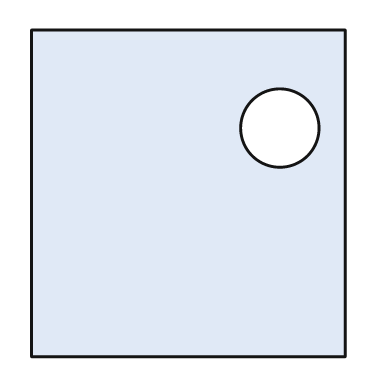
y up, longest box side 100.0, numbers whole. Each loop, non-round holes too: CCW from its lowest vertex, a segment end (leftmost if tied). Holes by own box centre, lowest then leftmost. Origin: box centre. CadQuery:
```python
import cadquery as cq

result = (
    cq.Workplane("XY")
    .moveTo(-48.0, -50.0)
    .lineTo(48.0, -50.0)
    .lineTo(48.0, 50.0)
    .lineTo(-48.0, 50.0)
    .close()
    .moveTo(28.0, 20.0)
    .circle(12.0)
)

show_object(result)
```